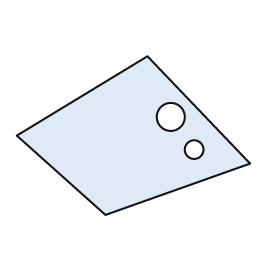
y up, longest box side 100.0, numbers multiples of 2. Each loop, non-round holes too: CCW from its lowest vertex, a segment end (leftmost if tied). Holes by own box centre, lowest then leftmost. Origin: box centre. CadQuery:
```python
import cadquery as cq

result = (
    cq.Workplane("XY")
    .moveTo(-12.0, -34.0)
    .lineTo(50.0, -12.0)
    .lineTo(6.0, 34.0)
    .lineTo(-50.0, 0.0)
    .close()
    .moveTo(26.0, -6.0)
    .circle(4.0)
    .moveTo(16.0, 8.0)
    .circle(6.0)
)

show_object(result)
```